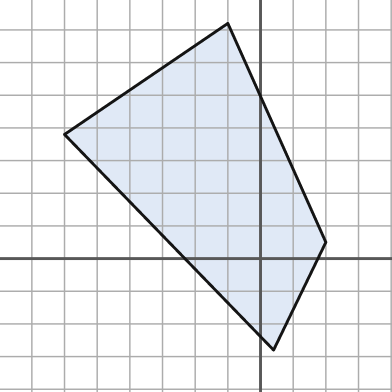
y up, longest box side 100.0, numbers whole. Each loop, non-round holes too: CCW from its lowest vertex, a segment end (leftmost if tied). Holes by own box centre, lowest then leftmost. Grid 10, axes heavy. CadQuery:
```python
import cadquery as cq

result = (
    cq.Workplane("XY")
    .moveTo(4.0, -28.0)
    .lineTo(20.0, 5.0)
    .lineTo(-10.0, 72.0)
    .lineTo(-60.0, 38.0)
    .close()
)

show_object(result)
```